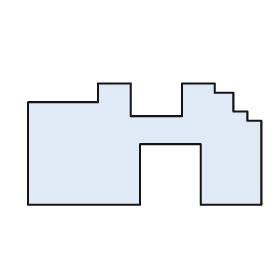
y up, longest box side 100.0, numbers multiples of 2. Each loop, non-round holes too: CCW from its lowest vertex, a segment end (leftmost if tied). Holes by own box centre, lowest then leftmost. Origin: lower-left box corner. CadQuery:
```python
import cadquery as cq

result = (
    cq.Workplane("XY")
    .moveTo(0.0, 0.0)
    .lineTo(48.0, 0.0)
    .lineTo(48.0, 26.0)
    .lineTo(74.0, 26.0)
    .lineTo(74.0, 0.0)
    .lineTo(100.0, 0.0)
    .lineTo(100.0, 36.0)
    .lineTo(94.0, 36.0)
    .lineTo(94.0, 40.0)
    .lineTo(88.0, 40.0)
    .lineTo(88.0, 48.0)
    .lineTo(80.0, 48.0)
    .lineTo(80.0, 52.0)
    .lineTo(66.0, 52.0)
    .lineTo(66.0, 38.0)
    .lineTo(44.0, 38.0)
    .lineTo(44.0, 52.0)
    .lineTo(30.0, 52.0)
    .lineTo(30.0, 44.0)
    .lineTo(0.0, 44.0)
    .close()
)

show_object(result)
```